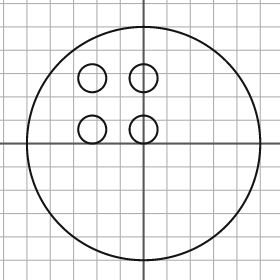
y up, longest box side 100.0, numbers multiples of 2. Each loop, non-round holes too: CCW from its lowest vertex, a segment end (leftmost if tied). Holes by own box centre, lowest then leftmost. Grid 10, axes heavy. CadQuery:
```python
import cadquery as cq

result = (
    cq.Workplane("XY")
    .moveTo(0.0, 0.0)
    .circle(50.0)
    .moveTo(-22.0, 6.0)
    .circle(6.0)
    .moveTo(0.0, 6.0)
    .circle(6.0)
    .moveTo(-22.0, 28.0)
    .circle(6.0)
    .moveTo(0.0, 28.0)
    .circle(6.0)
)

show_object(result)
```